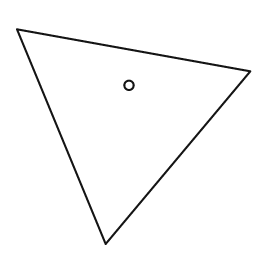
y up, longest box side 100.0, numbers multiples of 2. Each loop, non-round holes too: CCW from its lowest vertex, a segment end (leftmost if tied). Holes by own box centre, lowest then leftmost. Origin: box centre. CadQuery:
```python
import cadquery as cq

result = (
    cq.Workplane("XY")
    .moveTo(-12.0, -46.0)
    .lineTo(50.0, 28.0)
    .lineTo(-50.0, 46.0)
    .close()
    .moveTo(-2.0, 22.0)
    .circle(2.0)
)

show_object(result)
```